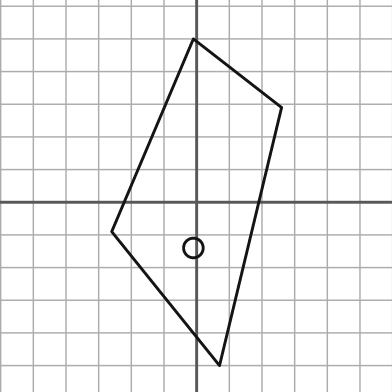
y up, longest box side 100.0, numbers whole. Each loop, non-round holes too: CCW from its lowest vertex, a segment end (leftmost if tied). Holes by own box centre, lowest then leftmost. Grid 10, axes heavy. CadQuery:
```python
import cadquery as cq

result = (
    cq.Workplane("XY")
    .moveTo(7.0, -50.0)
    .lineTo(26.0, 29.0)
    .lineTo(-1.0, 50.0)
    .lineTo(-26.0, -9.0)
    .close()
    .moveTo(-1.0, -14.0)
    .circle(3.0)
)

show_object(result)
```